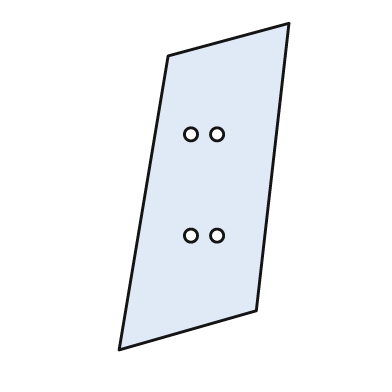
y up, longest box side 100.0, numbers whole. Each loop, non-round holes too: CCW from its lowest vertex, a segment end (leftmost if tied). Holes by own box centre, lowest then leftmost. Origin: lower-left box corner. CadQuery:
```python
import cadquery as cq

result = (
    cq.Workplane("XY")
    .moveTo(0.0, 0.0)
    .lineTo(42.0, 12.0)
    .lineTo(52.0, 100.0)
    .lineTo(15.0, 90.0)
    .close()
    .moveTo(22.0, 35.0)
    .circle(2.0)
    .moveTo(30.0, 35.0)
    .circle(2.0)
    .moveTo(22.0, 66.0)
    .circle(2.0)
    .moveTo(30.0, 66.0)
    .circle(2.0)
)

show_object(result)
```